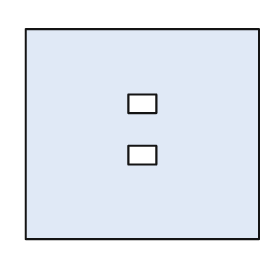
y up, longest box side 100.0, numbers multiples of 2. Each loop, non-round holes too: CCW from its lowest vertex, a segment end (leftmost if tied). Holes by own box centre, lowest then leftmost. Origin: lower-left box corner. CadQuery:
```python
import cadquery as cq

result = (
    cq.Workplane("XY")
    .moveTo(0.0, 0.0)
    .lineTo(100.0, 0.0)
    .lineTo(100.0, 90.0)
    .lineTo(0.0, 90.0)
    .close()
    .moveTo(44.0, 32.0)
    .lineTo(56.0, 32.0)
    .lineTo(56.0, 40.0)
    .lineTo(44.0, 40.0)
    .close()
    .moveTo(44.0, 54.0)
    .lineTo(56.0, 54.0)
    .lineTo(56.0, 62.0)
    .lineTo(44.0, 62.0)
    .close()
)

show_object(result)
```